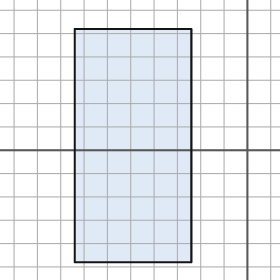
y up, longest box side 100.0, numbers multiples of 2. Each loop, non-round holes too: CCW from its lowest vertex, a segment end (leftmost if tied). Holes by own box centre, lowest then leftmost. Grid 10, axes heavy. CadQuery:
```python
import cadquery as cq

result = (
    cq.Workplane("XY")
    .moveTo(-74.0, -48.0)
    .lineTo(-24.0, -48.0)
    .lineTo(-24.0, 52.0)
    .lineTo(-74.0, 52.0)
    .close()
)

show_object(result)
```